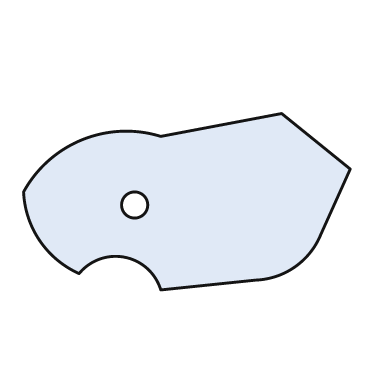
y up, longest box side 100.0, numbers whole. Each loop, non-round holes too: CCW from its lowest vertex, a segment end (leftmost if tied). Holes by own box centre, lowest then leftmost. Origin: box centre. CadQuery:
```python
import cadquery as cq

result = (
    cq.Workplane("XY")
    .moveTo(-8.0, -27.0)
    .lineTo(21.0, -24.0)
    .threePointArc((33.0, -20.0), (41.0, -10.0))
    .lineTo(50.0, 10.0)
    .lineTo(29.0, 27.0)
    .lineTo(-8.0, 20.0)
    .threePointArc((-32.0, 19.0), (-50.0, 3.0))
    .threePointArc((-45.0, -12.0), (-33.0, -22.0))
    .threePointArc((-19.0, -17.0), (-8.0, -27.0))
    .close()
    .moveTo(-16.0, -1.0)
    .circle(4.0)
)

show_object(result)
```